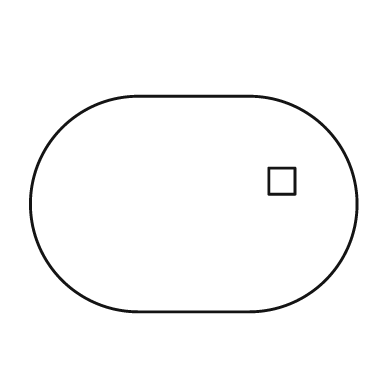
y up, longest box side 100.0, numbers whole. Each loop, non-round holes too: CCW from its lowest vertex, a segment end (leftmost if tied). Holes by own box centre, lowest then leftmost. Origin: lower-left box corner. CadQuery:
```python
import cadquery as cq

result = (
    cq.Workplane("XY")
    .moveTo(33.0, 0.0)
    .lineTo(67.0, 0.0)
    .threePointArc((100.0, 33.0), (67.0, 66.0))
    .lineTo(33.0, 66.0)
    .threePointArc((0.0, 33.0), (33.0, 0.0))
    .close()
    .moveTo(73.0, 36.0)
    .lineTo(81.0, 36.0)
    .lineTo(81.0, 44.0)
    .lineTo(73.0, 44.0)
    .close()
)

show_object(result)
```